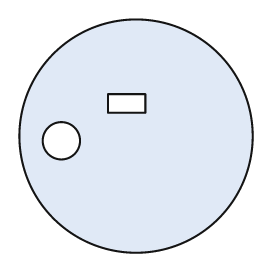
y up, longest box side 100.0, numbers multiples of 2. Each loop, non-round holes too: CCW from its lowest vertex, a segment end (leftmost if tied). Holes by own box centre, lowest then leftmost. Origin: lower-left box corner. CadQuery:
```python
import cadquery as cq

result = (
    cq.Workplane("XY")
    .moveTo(50.0, 50.0)
    .circle(50.0)
    .moveTo(18.0, 48.0)
    .circle(8.0)
    .moveTo(38.0, 60.0)
    .lineTo(54.0, 60.0)
    .lineTo(54.0, 68.0)
    .lineTo(38.0, 68.0)
    .close()
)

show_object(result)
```